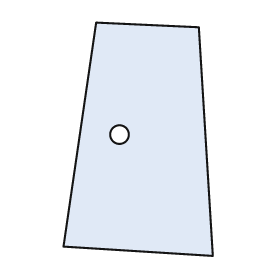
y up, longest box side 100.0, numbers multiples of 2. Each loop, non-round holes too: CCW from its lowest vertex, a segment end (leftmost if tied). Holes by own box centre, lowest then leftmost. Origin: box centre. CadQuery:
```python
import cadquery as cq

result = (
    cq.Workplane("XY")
    .moveTo(32.0, -50.0)
    .lineTo(26.0, 48.0)
    .lineTo(-18.0, 50.0)
    .lineTo(-32.0, -46.0)
    .close()
    .moveTo(-8.0, 2.0)
    .circle(4.0)
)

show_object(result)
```